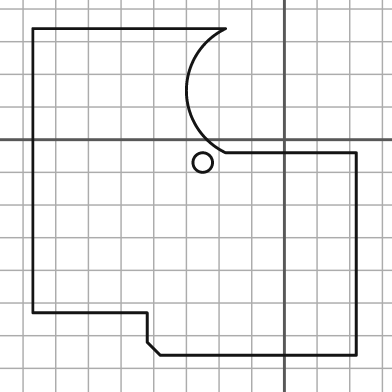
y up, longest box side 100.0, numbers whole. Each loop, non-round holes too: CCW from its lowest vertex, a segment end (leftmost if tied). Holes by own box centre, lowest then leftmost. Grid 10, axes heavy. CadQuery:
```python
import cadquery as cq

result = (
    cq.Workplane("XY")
    .moveTo(-38.0, -66.0)
    .lineTo(22.0, -66.0)
    .lineTo(22.0, -4.0)
    .lineTo(-18.0, -4.0)
    .threePointArc((-30.0, 15.0), (-18.0, 34.0))
    .lineTo(-77.0, 34.0)
    .lineTo(-77.0, -53.0)
    .lineTo(-42.0, -53.0)
    .lineTo(-42.0, -62.0)
    .close()
    .moveTo(-25.0, -7.0)
    .circle(3.0)
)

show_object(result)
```